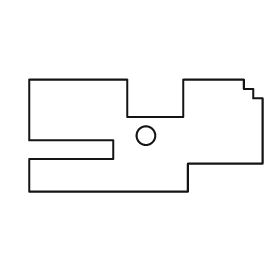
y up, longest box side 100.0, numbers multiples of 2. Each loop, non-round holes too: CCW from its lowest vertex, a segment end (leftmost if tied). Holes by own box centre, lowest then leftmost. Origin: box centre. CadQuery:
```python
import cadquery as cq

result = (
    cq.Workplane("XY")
    .moveTo(-50.0, -24.0)
    .lineTo(18.0, -24.0)
    .lineTo(18.0, -12.0)
    .lineTo(50.0, -12.0)
    .lineTo(50.0, 16.0)
    .lineTo(46.0, 16.0)
    .lineTo(46.0, 20.0)
    .lineTo(42.0, 20.0)
    .lineTo(42.0, 24.0)
    .lineTo(16.0, 24.0)
    .lineTo(16.0, 8.0)
    .lineTo(-8.0, 8.0)
    .lineTo(-8.0, 24.0)
    .lineTo(-50.0, 24.0)
    .lineTo(-50.0, -2.0)
    .lineTo(-14.0, -2.0)
    .lineTo(-14.0, -10.0)
    .lineTo(-50.0, -10.0)
    .close()
    .moveTo(0.0, 0.0)
    .circle(4.0)
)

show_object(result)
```